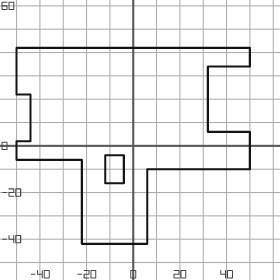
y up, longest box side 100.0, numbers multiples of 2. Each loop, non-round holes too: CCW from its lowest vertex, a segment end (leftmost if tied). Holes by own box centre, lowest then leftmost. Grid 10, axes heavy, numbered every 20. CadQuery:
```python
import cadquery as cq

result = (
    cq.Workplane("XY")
    .moveTo(-22.0, -42.0)
    .lineTo(6.0, -42.0)
    .lineTo(6.0, -10.0)
    .lineTo(50.0, -10.0)
    .lineTo(50.0, 6.0)
    .lineTo(32.0, 6.0)
    .lineTo(32.0, 34.0)
    .lineTo(50.0, 34.0)
    .lineTo(50.0, 42.0)
    .lineTo(-50.0, 42.0)
    .lineTo(-50.0, 22.0)
    .lineTo(-44.0, 22.0)
    .lineTo(-44.0, 2.0)
    .lineTo(-50.0, 2.0)
    .lineTo(-50.0, -6.0)
    .lineTo(-22.0, -6.0)
    .close()
    .moveTo(-12.0, -16.0)
    .lineTo(-4.0, -16.0)
    .lineTo(-4.0, -4.0)
    .lineTo(-12.0, -4.0)
    .close()
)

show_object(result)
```